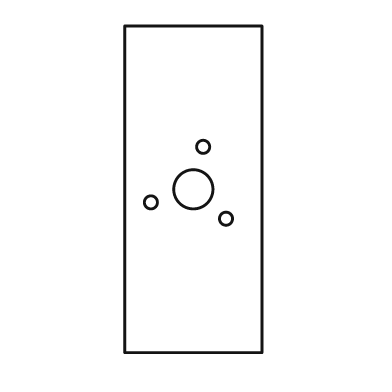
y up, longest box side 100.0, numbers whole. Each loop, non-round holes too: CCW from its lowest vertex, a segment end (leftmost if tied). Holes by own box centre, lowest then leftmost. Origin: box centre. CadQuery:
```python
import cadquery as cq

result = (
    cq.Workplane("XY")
    .moveTo(-21.0, -50.0)
    .lineTo(21.0, -50.0)
    .lineTo(21.0, 50.0)
    .lineTo(-21.0, 50.0)
    .close()
    .moveTo(10.0, -9.0)
    .circle(2.0)
    .moveTo(-13.0, -4.0)
    .circle(2.0)
    .moveTo(0.0, 0.0)
    .circle(6.0)
    .moveTo(3.0, 13.0)
    .circle(2.0)
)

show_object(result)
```